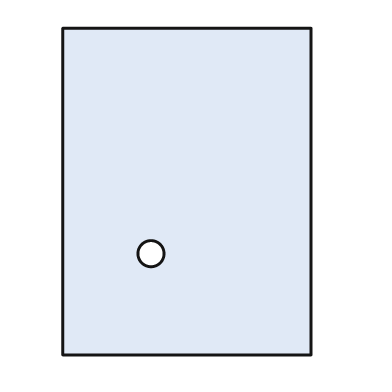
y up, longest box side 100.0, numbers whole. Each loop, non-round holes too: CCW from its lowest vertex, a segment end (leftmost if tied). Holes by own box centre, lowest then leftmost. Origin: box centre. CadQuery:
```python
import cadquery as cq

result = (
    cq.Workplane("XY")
    .moveTo(-38.0, -50.0)
    .lineTo(38.0, -50.0)
    .lineTo(38.0, 50.0)
    .lineTo(-38.0, 50.0)
    .close()
    .moveTo(-11.0, -19.0)
    .circle(4.0)
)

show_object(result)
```